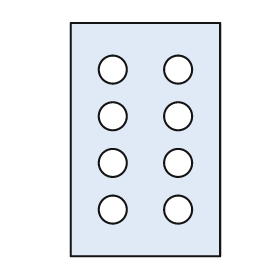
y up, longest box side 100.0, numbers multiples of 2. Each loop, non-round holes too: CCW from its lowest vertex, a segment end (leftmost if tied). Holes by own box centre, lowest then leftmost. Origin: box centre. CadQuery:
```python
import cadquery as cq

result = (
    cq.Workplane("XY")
    .moveTo(-32.0, -50.0)
    .lineTo(32.0, -50.0)
    .lineTo(32.0, 50.0)
    .lineTo(-32.0, 50.0)
    .close()
    .moveTo(-14.0, -30.0)
    .circle(6.0)
    .moveTo(14.0, -30.0)
    .circle(6.0)
    .moveTo(-14.0, -10.0)
    .circle(6.0)
    .moveTo(14.0, -10.0)
    .circle(6.0)
    .moveTo(-14.0, 10.0)
    .circle(6.0)
    .moveTo(14.0, 10.0)
    .circle(6.0)
    .moveTo(-14.0, 30.0)
    .circle(6.0)
    .moveTo(14.0, 30.0)
    .circle(6.0)
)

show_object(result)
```